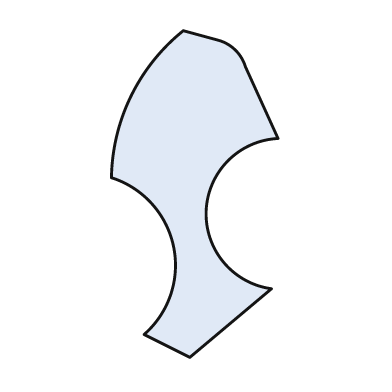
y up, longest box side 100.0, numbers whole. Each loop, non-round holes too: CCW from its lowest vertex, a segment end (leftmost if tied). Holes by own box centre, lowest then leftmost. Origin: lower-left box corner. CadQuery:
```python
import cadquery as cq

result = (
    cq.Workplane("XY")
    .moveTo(24.0, 0.0)
    .lineTo(49.0, 21.0)
    .threePointArc((29.0, 45.0), (51.0, 67.0))
    .lineTo(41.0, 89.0)
    .threePointArc((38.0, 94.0), (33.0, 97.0))
    .lineTo(22.0, 100.0)
    .threePointArc((6.0, 80.0), (0.0, 55.0))
    .threePointArc((19.0, 34.0), (10.0, 7.0))
    .close()
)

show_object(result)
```